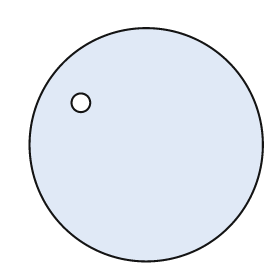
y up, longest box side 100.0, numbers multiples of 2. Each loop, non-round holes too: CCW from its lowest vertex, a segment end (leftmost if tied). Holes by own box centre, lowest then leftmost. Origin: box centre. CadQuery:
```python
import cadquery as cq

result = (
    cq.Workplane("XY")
    .moveTo(0.0, 0.0)
    .circle(50.0)
    .moveTo(-28.0, 18.0)
    .circle(4.0)
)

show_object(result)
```